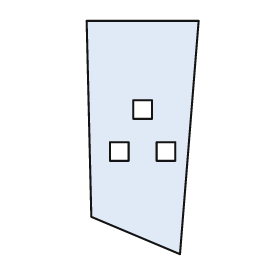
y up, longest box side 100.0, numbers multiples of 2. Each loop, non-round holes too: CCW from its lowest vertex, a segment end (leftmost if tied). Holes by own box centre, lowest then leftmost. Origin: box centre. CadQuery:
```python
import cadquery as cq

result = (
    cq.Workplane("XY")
    .moveTo(16.0, -50.0)
    .lineTo(24.0, 50.0)
    .lineTo(-24.0, 50.0)
    .lineTo(-22.0, -34.0)
    .close()
    .moveTo(-14.0, -10.0)
    .lineTo(-6.0, -10.0)
    .lineTo(-6.0, -2.0)
    .lineTo(-14.0, -2.0)
    .close()
    .moveTo(6.0, -10.0)
    .lineTo(14.0, -10.0)
    .lineTo(14.0, -2.0)
    .lineTo(6.0, -2.0)
    .close()
    .moveTo(-4.0, 8.0)
    .lineTo(4.0, 8.0)
    .lineTo(4.0, 16.0)
    .lineTo(-4.0, 16.0)
    .close()
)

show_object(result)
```